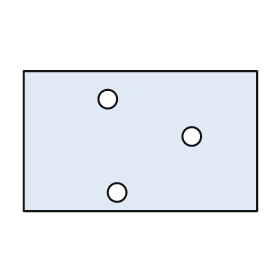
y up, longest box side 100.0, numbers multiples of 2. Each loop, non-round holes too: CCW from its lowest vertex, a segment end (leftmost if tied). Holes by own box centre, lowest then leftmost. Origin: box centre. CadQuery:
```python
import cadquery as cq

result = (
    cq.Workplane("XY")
    .moveTo(-50.0, -30.0)
    .lineTo(50.0, -30.0)
    .lineTo(50.0, 30.0)
    .lineTo(-50.0, 30.0)
    .close()
    .moveTo(-10.0, -22.0)
    .circle(4.0)
    .moveTo(22.0, 2.0)
    .circle(4.0)
    .moveTo(-14.0, 18.0)
    .circle(4.0)
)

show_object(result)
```